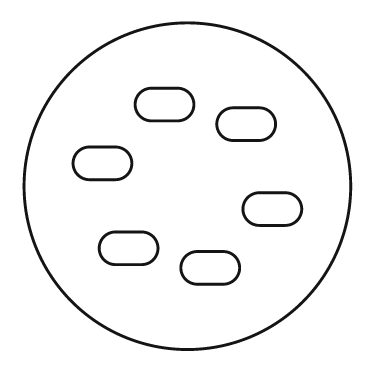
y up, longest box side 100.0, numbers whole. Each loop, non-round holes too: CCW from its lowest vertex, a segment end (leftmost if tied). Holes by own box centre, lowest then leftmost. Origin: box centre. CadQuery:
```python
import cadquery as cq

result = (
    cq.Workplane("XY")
    .moveTo(0.0, 0.0)
    .circle(50.0)
    .moveTo(3.0, -30.0)
    .lineTo(11.0, -30.0)
    .threePointArc((16.0, -25.0), (11.0, -20.0))
    .lineTo(3.0, -20.0)
    .threePointArc((-2.0, -25.0), (3.0, -30.0))
    .close()
    .moveTo(-22.0, -24.0)
    .lineTo(-14.0, -24.0)
    .threePointArc((-9.0, -19.0), (-14.0, -14.0))
    .lineTo(-22.0, -14.0)
    .threePointArc((-27.0, -19.0), (-22.0, -24.0))
    .close()
    .moveTo(22.0, -12.0)
    .lineTo(30.0, -12.0)
    .threePointArc((35.0, -7.0), (30.0, -2.0))
    .lineTo(22.0, -2.0)
    .threePointArc((17.0, -7.0), (22.0, -12.0))
    .close()
    .moveTo(-30.0, 2.0)
    .lineTo(-22.0, 2.0)
    .threePointArc((-17.0, 7.0), (-22.0, 12.0))
    .lineTo(-30.0, 12.0)
    .threePointArc((-35.0, 7.0), (-30.0, 2.0))
    .close()
    .moveTo(14.0, 14.0)
    .lineTo(22.0, 14.0)
    .threePointArc((27.0, 19.0), (22.0, 24.0))
    .lineTo(14.0, 24.0)
    .threePointArc((9.0, 19.0), (14.0, 14.0))
    .close()
    .moveTo(-11.0, 20.0)
    .lineTo(-3.0, 20.0)
    .threePointArc((2.0, 25.0), (-3.0, 30.0))
    .lineTo(-11.0, 30.0)
    .threePointArc((-16.0, 25.0), (-11.0, 20.0))
    .close()
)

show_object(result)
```